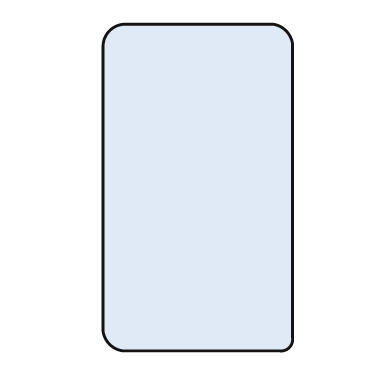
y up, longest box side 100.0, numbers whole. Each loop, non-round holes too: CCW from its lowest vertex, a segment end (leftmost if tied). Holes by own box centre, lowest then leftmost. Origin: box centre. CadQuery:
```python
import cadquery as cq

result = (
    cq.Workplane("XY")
    .moveTo(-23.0, -50.0)
    .lineTo(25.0, -50.0)
    .threePointArc((28.0, -49.0), (29.0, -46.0))
    .lineTo(29.0, 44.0)
    .threePointArc((27.0, 48.0), (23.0, 50.0))
    .lineTo(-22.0, 50.0)
    .threePointArc((-27.0, 48.0), (-29.0, 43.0))
    .lineTo(-29.0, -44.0)
    .threePointArc((-27.0, -48.0), (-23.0, -50.0))
    .close()
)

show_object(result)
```